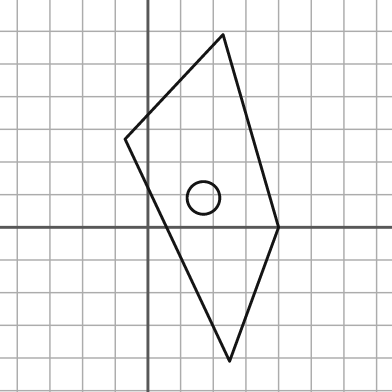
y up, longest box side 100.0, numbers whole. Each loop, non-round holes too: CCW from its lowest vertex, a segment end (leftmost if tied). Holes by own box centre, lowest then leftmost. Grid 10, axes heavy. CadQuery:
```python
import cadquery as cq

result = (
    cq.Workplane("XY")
    .moveTo(25.0, -41.0)
    .lineTo(40.0, 0.0)
    .lineTo(23.0, 59.0)
    .lineTo(-7.0, 27.0)
    .close()
    .moveTo(17.0, 9.0)
    .circle(5.0)
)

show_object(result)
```